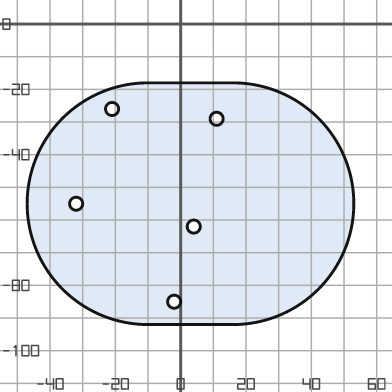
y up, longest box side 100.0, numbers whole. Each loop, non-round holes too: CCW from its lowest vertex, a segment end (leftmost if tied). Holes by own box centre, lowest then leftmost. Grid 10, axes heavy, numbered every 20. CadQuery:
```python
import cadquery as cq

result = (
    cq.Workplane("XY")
    .moveTo(-10.0, -92.0)
    .lineTo(16.0, -92.0)
    .threePointArc((53.0, -55.0), (16.0, -18.0))
    .lineTo(-10.0, -18.0)
    .threePointArc((-47.0, -55.0), (-10.0, -92.0))
    .close()
    .moveTo(-2.0, -85.0)
    .circle(2.0)
    .moveTo(4.0, -62.0)
    .circle(2.0)
    .moveTo(-32.0, -55.0)
    .circle(2.0)
    .moveTo(11.0, -29.0)
    .circle(2.0)
    .moveTo(-21.0, -26.0)
    .circle(2.0)
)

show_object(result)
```